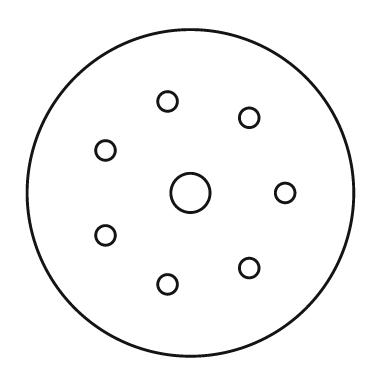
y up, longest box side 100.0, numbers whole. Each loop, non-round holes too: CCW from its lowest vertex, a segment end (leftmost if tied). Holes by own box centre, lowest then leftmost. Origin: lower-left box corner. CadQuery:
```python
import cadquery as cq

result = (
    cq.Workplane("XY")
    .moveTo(50.0, 50.0)
    .circle(50.0)
    .moveTo(43.0, 22.0)
    .circle(3.0)
    .moveTo(68.0, 27.0)
    .circle(3.0)
    .moveTo(24.0, 37.0)
    .circle(3.0)
    .moveTo(50.0, 50.0)
    .circle(6.0)
    .moveTo(79.0, 50.0)
    .circle(3.0)
    .moveTo(24.0, 63.0)
    .circle(3.0)
    .moveTo(68.0, 73.0)
    .circle(3.0)
    .moveTo(43.0, 78.0)
    .circle(3.0)
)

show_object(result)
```